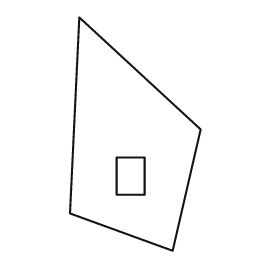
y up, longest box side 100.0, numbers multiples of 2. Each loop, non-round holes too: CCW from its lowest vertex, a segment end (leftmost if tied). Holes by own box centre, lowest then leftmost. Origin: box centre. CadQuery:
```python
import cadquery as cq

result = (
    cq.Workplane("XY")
    .moveTo(16.0, -50.0)
    .lineTo(28.0, 2.0)
    .lineTo(-24.0, 50.0)
    .lineTo(-28.0, -34.0)
    .close()
    .moveTo(-8.0, -26.0)
    .lineTo(4.0, -26.0)
    .lineTo(4.0, -10.0)
    .lineTo(-8.0, -10.0)
    .close()
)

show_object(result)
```